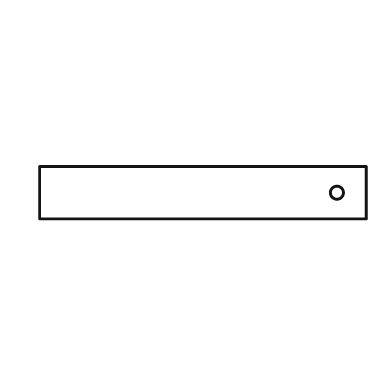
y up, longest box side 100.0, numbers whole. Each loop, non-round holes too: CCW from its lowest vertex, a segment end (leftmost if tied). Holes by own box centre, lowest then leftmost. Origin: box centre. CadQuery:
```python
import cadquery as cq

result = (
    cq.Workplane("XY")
    .moveTo(-50.0, -8.0)
    .lineTo(50.0, -8.0)
    .lineTo(50.0, 8.0)
    .lineTo(-50.0, 8.0)
    .close()
    .moveTo(41.0, 0.0)
    .circle(2.0)
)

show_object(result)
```